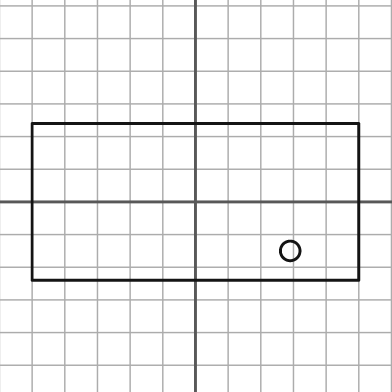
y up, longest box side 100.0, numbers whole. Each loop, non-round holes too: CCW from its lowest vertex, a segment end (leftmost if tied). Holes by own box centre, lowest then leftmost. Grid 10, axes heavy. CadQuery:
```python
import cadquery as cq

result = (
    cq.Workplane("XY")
    .moveTo(-50.0, -24.0)
    .lineTo(50.0, -24.0)
    .lineTo(50.0, 24.0)
    .lineTo(-50.0, 24.0)
    .close()
    .moveTo(29.0, -15.0)
    .circle(3.0)
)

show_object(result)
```